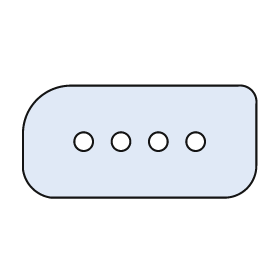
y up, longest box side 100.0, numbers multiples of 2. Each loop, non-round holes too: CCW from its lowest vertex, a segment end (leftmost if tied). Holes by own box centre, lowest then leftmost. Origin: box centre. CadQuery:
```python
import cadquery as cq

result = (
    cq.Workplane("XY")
    .moveTo(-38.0, -24.0)
    .lineTo(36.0, -24.0)
    .threePointArc((46.0, -20.0), (50.0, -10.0))
    .lineTo(50.0, 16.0)
    .threePointArc((48.0, 22.0), (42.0, 24.0))
    .lineTo(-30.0, 24.0)
    .threePointArc((-44.0, 18.0), (-50.0, 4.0))
    .lineTo(-50.0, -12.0)
    .threePointArc((-46.0, -20.0), (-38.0, -24.0))
    .close()
    .moveTo(-24.0, 0.0)
    .circle(4.0)
    .moveTo(-8.0, 0.0)
    .circle(4.0)
    .moveTo(8.0, 0.0)
    .circle(4.0)
    .moveTo(24.0, 0.0)
    .circle(4.0)
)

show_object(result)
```